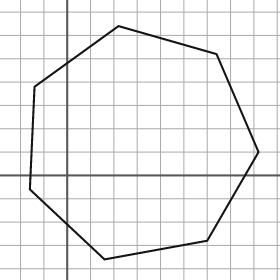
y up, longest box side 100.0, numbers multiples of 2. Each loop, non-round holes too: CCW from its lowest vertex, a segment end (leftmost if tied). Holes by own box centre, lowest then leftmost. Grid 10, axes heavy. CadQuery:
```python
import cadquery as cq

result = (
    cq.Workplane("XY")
    .moveTo(16.0, -36.0)
    .lineTo(60.0, -28.0)
    .lineTo(82.0, 10.0)
    .lineTo(64.0, 52.0)
    .lineTo(22.0, 64.0)
    .lineTo(-14.0, 38.0)
    .lineTo(-16.0, -6.0)
    .close()
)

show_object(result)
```